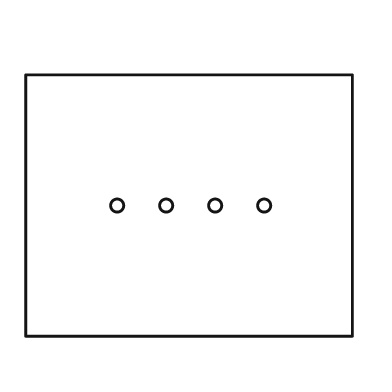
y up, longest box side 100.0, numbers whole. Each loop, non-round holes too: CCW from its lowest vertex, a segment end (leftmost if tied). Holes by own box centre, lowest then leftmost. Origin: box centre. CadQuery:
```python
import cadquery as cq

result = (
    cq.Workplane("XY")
    .moveTo(-50.0, -40.0)
    .lineTo(50.0, -40.0)
    .lineTo(50.0, 40.0)
    .lineTo(-50.0, 40.0)
    .close()
    .moveTo(-22.0, 0.0)
    .circle(2.0)
    .moveTo(-7.0, 0.0)
    .circle(2.0)
    .moveTo(8.0, 0.0)
    .circle(2.0)
    .moveTo(23.0, 0.0)
    .circle(2.0)
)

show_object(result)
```